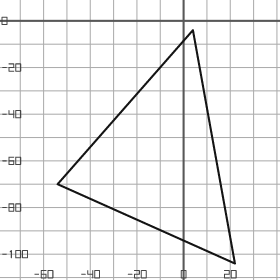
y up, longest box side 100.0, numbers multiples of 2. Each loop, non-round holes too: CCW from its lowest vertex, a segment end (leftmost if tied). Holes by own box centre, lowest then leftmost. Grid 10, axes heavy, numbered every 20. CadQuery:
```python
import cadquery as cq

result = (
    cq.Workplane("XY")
    .moveTo(22.0, -104.0)
    .lineTo(4.0, -4.0)
    .lineTo(-54.0, -70.0)
    .close()
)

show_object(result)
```